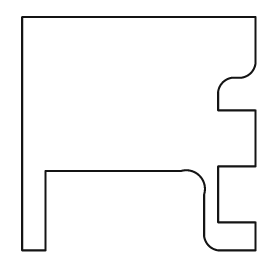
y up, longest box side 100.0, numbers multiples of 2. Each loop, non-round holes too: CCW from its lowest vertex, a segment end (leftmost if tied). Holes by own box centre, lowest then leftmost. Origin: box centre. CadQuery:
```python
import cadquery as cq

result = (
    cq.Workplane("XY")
    .moveTo(-50.0, -50.0)
    .lineTo(-40.0, -50.0)
    .lineTo(-40.0, -16.0)
    .lineTo(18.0, -16.0)
    .threePointArc((26.0, -18.0), (28.0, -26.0))
    .lineTo(28.0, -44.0)
    .threePointArc((30.0, -48.0), (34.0, -50.0))
    .lineTo(50.0, -50.0)
    .lineTo(50.0, -38.0)
    .lineTo(34.0, -38.0)
    .lineTo(34.0, -14.0)
    .lineTo(50.0, -14.0)
    .lineTo(50.0, 10.0)
    .lineTo(34.0, 10.0)
    .lineTo(34.0, 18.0)
    .threePointArc((36.0, 22.0), (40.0, 24.0))
    .lineTo(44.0, 24.0)
    .threePointArc((48.0, 26.0), (50.0, 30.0))
    .lineTo(50.0, 50.0)
    .lineTo(-50.0, 50.0)
    .close()
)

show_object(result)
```